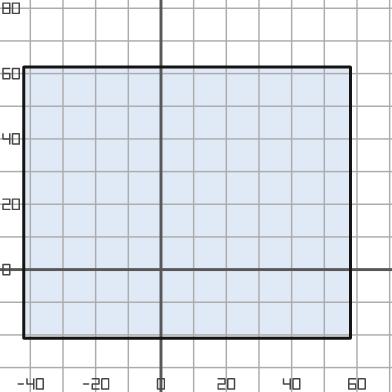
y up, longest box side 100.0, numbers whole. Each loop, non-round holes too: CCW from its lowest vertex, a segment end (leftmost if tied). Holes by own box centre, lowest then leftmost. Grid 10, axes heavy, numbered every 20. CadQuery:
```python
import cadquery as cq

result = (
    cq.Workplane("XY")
    .moveTo(-42.0, -21.0)
    .lineTo(58.0, -21.0)
    .lineTo(58.0, 62.0)
    .lineTo(-42.0, 62.0)
    .close()
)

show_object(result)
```